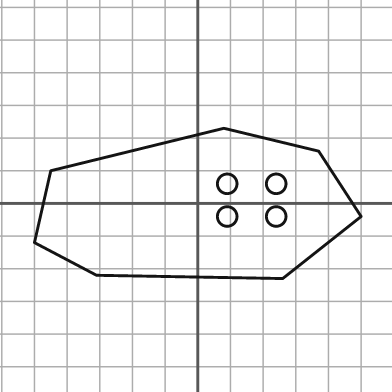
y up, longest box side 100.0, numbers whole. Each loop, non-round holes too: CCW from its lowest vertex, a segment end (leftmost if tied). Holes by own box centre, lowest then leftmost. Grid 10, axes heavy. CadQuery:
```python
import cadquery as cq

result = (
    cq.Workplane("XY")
    .moveTo(26.0, -23.0)
    .lineTo(50.0, -4.0)
    .lineTo(37.0, 16.0)
    .lineTo(8.0, 23.0)
    .lineTo(-45.0, 10.0)
    .lineTo(-50.0, -12.0)
    .lineTo(-31.0, -22.0)
    .close()
    .moveTo(9.0, -4.0)
    .circle(3.0)
    .moveTo(24.0, -4.0)
    .circle(3.0)
    .moveTo(9.0, 6.0)
    .circle(3.0)
    .moveTo(24.0, 6.0)
    .circle(3.0)
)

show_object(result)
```